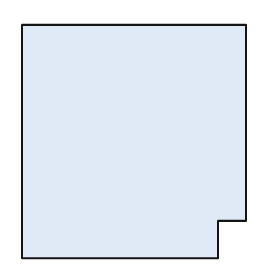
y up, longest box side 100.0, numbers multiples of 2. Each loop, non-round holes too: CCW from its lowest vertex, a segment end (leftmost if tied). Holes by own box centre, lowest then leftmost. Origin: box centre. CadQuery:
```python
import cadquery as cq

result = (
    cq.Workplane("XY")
    .moveTo(-48.0, -50.0)
    .lineTo(36.0, -50.0)
    .lineTo(36.0, -34.0)
    .lineTo(48.0, -34.0)
    .lineTo(48.0, 50.0)
    .lineTo(-48.0, 50.0)
    .close()
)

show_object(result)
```